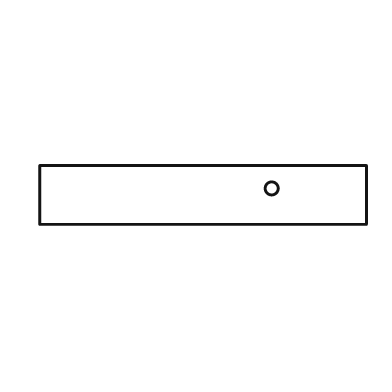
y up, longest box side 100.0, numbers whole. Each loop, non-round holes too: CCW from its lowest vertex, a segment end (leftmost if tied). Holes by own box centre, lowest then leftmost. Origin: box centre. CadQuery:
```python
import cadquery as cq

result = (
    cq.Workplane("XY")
    .moveTo(-50.0, -9.0)
    .lineTo(50.0, -9.0)
    .lineTo(50.0, 9.0)
    .lineTo(-50.0, 9.0)
    .close()
    .moveTo(21.0, 2.0)
    .circle(2.0)
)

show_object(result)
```